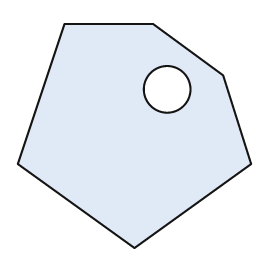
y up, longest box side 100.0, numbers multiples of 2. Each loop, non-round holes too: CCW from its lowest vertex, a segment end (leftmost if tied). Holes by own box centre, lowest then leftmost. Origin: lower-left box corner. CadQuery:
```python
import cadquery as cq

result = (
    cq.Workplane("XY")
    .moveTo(50.0, 0.0)
    .lineTo(100.0, 36.0)
    .lineTo(88.0, 74.0)
    .lineTo(58.0, 96.0)
    .lineTo(20.0, 96.0)
    .lineTo(0.0, 36.0)
    .close()
    .moveTo(64.0, 68.0)
    .circle(10.0)
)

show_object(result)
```